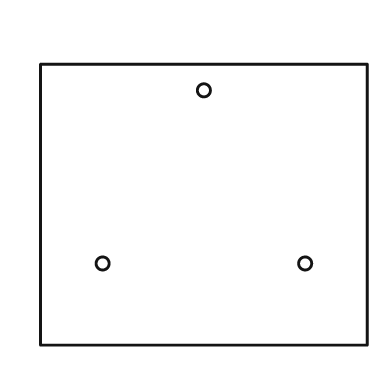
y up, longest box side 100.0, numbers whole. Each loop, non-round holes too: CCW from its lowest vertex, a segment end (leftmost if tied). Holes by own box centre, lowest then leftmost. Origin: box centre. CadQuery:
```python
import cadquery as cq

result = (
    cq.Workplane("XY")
    .moveTo(-50.0, -43.0)
    .lineTo(50.0, -43.0)
    .lineTo(50.0, 43.0)
    .lineTo(-50.0, 43.0)
    .close()
    .moveTo(-31.0, -18.0)
    .circle(2.0)
    .moveTo(31.0, -18.0)
    .circle(2.0)
    .moveTo(0.0, 35.0)
    .circle(2.0)
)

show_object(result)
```